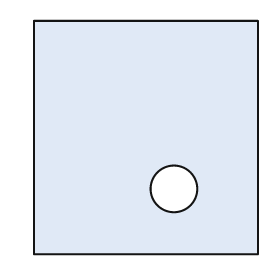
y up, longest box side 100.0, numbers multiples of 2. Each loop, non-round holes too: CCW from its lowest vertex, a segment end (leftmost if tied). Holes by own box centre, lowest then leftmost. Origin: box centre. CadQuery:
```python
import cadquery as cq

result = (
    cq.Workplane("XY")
    .moveTo(-48.0, -50.0)
    .lineTo(48.0, -50.0)
    .lineTo(48.0, 50.0)
    .lineTo(-48.0, 50.0)
    .close()
    .moveTo(12.0, -22.0)
    .circle(10.0)
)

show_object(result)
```